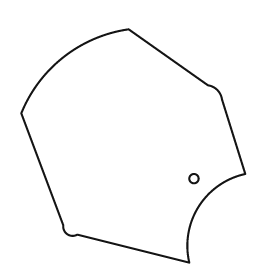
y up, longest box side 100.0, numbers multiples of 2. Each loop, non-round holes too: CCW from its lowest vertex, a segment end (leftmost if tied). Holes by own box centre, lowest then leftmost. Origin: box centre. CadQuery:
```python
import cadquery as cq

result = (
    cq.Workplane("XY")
    .moveTo(24.0, -50.0)
    .threePointArc((28.0, -26.0), (48.0, -12.0))
    .lineTo(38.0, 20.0)
    .threePointArc((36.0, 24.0), (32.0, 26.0))
    .lineTo(-2.0, 50.0)
    .threePointArc((-30.0, 38.0), (-48.0, 14.0))
    .lineTo(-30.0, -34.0)
    .threePointArc((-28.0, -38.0), (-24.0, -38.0))
    .close()
    .moveTo(26.0, -14.0)
    .circle(2.0)
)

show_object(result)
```